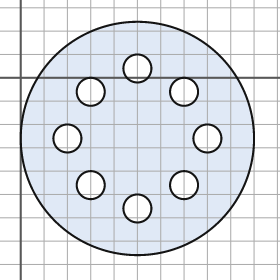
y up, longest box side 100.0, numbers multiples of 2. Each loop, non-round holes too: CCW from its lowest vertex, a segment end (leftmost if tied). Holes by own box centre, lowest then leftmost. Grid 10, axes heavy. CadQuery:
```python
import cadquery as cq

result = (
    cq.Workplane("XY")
    .moveTo(50.0, -26.0)
    .circle(50.0)
    .moveTo(50.0, -56.0)
    .circle(6.0)
    .moveTo(30.0, -46.0)
    .circle(6.0)
    .moveTo(70.0, -46.0)
    .circle(6.0)
    .moveTo(20.0, -26.0)
    .circle(6.0)
    .moveTo(80.0, -26.0)
    .circle(6.0)
    .moveTo(30.0, -6.0)
    .circle(6.0)
    .moveTo(70.0, -6.0)
    .circle(6.0)
    .moveTo(50.0, 4.0)
    .circle(6.0)
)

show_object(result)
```